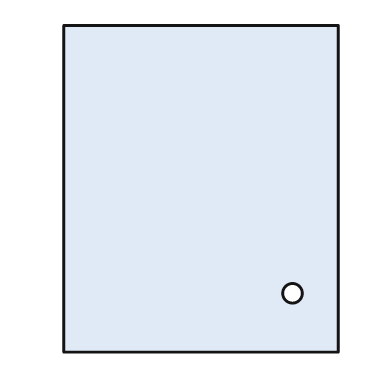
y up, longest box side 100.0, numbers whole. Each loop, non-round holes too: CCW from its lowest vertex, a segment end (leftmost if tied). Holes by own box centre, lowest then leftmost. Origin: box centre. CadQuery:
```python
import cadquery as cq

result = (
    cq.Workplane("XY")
    .moveTo(-42.0, -50.0)
    .lineTo(42.0, -50.0)
    .lineTo(42.0, 50.0)
    .lineTo(-42.0, 50.0)
    .close()
    .moveTo(28.0, -32.0)
    .circle(3.0)
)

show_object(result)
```